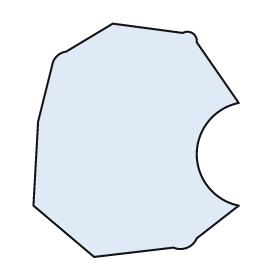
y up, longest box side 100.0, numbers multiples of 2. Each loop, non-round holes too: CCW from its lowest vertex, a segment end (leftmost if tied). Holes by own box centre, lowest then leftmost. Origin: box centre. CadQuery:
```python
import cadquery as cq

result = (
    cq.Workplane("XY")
    .moveTo(-18.0, -50.0)
    .lineTo(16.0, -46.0)
    .threePointArc((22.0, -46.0), (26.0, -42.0))
    .lineTo(44.0, -28.0)
    .threePointArc((26.0, -6.0), (44.0, 16.0))
    .lineTo(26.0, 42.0)
    .threePointArc((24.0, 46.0), (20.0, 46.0))
    .lineTo(-10.0, 50.0)
    .lineTo(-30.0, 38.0)
    .threePointArc((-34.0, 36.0), (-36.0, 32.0))
    .lineTo(-42.0, 8.0)
    .lineTo(-44.0, -28.0)
    .close()
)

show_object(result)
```